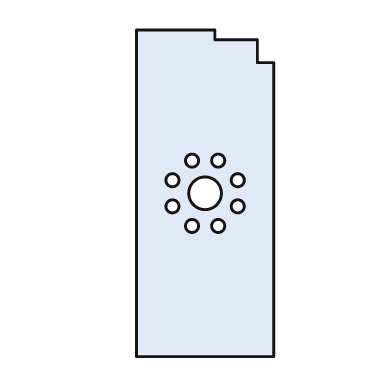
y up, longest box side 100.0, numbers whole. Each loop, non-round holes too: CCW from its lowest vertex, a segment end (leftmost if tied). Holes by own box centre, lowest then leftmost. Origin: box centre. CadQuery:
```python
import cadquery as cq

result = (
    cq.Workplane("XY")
    .moveTo(-21.0, -50.0)
    .lineTo(21.0, -50.0)
    .lineTo(21.0, 40.0)
    .lineTo(16.0, 40.0)
    .lineTo(16.0, 47.0)
    .lineTo(3.0, 47.0)
    .lineTo(3.0, 50.0)
    .lineTo(-21.0, 50.0)
    .close()
    .moveTo(-4.0, -10.0)
    .circle(2.0)
    .moveTo(4.0, -10.0)
    .circle(2.0)
    .moveTo(-10.0, -4.0)
    .circle(2.0)
    .moveTo(10.0, -4.0)
    .circle(2.0)
    .moveTo(0.0, 0.0)
    .circle(5.0)
    .moveTo(-10.0, 4.0)
    .circle(2.0)
    .moveTo(10.0, 4.0)
    .circle(2.0)
    .moveTo(-4.0, 10.0)
    .circle(2.0)
    .moveTo(4.0, 10.0)
    .circle(2.0)
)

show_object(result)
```